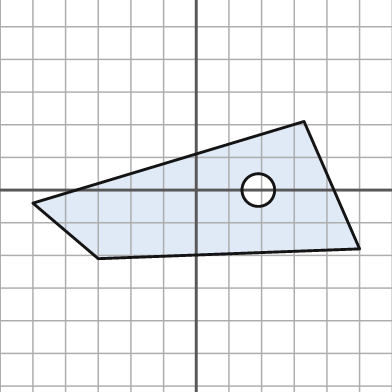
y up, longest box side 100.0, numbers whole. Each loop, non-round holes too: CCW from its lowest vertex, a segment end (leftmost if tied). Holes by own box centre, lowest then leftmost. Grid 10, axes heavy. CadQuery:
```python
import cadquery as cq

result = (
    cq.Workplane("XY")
    .moveTo(-30.0, -21.0)
    .lineTo(50.0, -18.0)
    .lineTo(33.0, 21.0)
    .lineTo(-50.0, -4.0)
    .close()
    .moveTo(19.0, 0.0)
    .circle(5.0)
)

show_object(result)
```